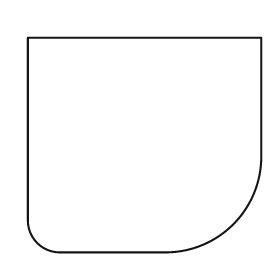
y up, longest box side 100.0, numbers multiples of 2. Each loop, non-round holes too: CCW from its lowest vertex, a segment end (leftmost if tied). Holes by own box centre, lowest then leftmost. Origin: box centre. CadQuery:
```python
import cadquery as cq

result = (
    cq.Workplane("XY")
    .moveTo(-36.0, -46.0)
    .lineTo(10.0, -46.0)
    .threePointArc((38.0, -34.0), (50.0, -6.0))
    .lineTo(50.0, 46.0)
    .lineTo(-50.0, 46.0)
    .lineTo(-50.0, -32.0)
    .threePointArc((-46.0, -42.0), (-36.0, -46.0))
    .close()
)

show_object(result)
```